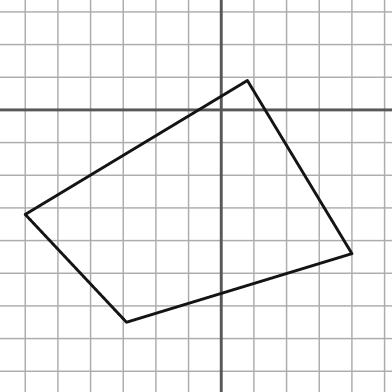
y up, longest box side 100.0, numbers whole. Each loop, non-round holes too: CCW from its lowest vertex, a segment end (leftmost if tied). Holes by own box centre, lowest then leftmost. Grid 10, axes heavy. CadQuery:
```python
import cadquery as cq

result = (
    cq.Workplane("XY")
    .moveTo(-29.0, -65.0)
    .lineTo(40.0, -44.0)
    .lineTo(8.0, 9.0)
    .lineTo(-60.0, -32.0)
    .close()
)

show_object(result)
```